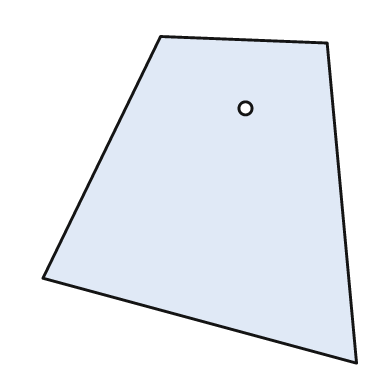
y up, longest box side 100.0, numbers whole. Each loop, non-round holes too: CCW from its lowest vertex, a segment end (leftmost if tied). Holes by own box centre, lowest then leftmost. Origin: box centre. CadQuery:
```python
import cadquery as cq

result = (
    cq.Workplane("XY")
    .moveTo(48.0, -50.0)
    .lineTo(39.0, 48.0)
    .lineTo(-12.0, 50.0)
    .lineTo(-48.0, -24.0)
    .close()
    .moveTo(14.0, 28.0)
    .circle(2.0)
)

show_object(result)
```